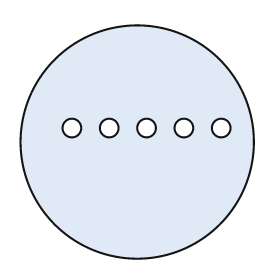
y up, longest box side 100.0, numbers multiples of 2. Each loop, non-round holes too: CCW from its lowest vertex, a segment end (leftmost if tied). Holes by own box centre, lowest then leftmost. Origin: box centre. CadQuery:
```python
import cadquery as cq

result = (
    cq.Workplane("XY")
    .moveTo(0.0, 0.0)
    .circle(50.0)
    .moveTo(-28.0, 6.0)
    .circle(4.0)
    .moveTo(-12.0, 6.0)
    .circle(4.0)
    .moveTo(4.0, 6.0)
    .circle(4.0)
    .moveTo(20.0, 6.0)
    .circle(4.0)
    .moveTo(36.0, 6.0)
    .circle(4.0)
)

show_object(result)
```